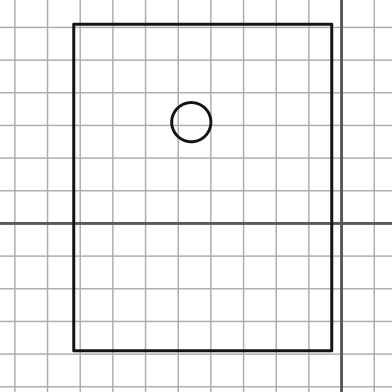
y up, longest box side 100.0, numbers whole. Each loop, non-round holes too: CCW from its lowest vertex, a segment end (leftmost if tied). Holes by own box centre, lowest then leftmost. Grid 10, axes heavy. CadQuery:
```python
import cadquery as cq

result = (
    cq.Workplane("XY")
    .moveTo(-82.0, -39.0)
    .lineTo(-3.0, -39.0)
    .lineTo(-3.0, 61.0)
    .lineTo(-82.0, 61.0)
    .close()
    .moveTo(-46.0, 31.0)
    .circle(6.0)
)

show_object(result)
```